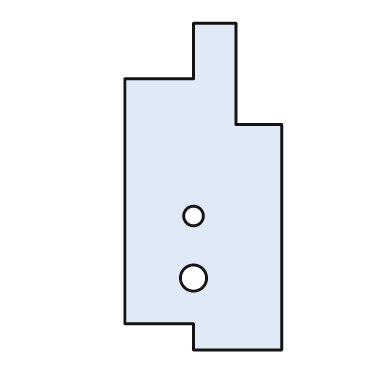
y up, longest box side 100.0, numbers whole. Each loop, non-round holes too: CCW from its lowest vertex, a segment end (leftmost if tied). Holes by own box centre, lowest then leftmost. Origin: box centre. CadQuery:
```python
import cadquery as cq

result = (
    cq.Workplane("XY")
    .moveTo(-3.0, -50.0)
    .lineTo(24.0, -50.0)
    .lineTo(24.0, 19.0)
    .lineTo(10.0, 19.0)
    .lineTo(10.0, 50.0)
    .lineTo(-3.0, 50.0)
    .lineTo(-3.0, 33.0)
    .lineTo(-24.0, 33.0)
    .lineTo(-24.0, -42.0)
    .lineTo(-3.0, -42.0)
    .close()
    .moveTo(-3.0, -28.0)
    .circle(4.0)
    .moveTo(-3.0, -9.0)
    .circle(3.0)
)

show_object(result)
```